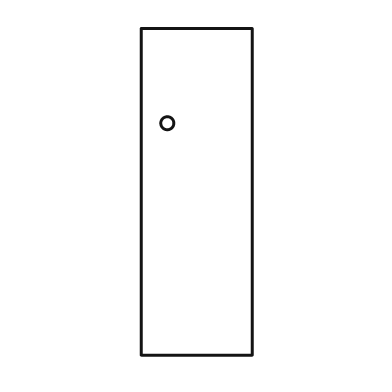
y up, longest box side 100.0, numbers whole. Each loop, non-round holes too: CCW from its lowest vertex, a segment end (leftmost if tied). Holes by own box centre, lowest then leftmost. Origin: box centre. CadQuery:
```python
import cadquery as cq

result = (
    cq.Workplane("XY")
    .moveTo(-17.0, -50.0)
    .lineTo(17.0, -50.0)
    .lineTo(17.0, 50.0)
    .lineTo(-17.0, 50.0)
    .close()
    .moveTo(-9.0, 21.0)
    .circle(2.0)
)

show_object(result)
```